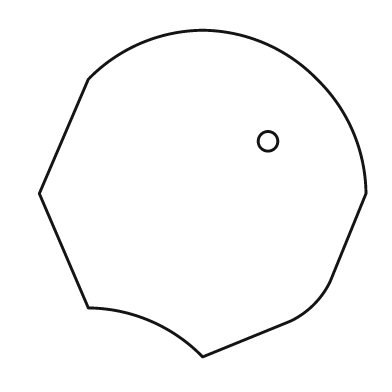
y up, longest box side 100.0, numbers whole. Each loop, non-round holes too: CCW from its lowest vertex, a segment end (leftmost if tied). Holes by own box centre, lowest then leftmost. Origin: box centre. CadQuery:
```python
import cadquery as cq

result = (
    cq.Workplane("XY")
    .moveTo(0.0, -50.0)
    .lineTo(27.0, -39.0)
    .threePointArc((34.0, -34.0), (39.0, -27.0))
    .lineTo(50.0, 0.0)
    .threePointArc((46.0, 19.0), (35.0, 35.0))
    .threePointArc((19.0, 46.0), (0.0, 50.0))
    .threePointArc((-19.0, 46.0), (-35.0, 35.0))
    .lineTo(-50.0, 0.0)
    .lineTo(-35.0, -35.0)
    .threePointArc((-16.0, -39.0), (0.0, -50.0))
    .close()
    .moveTo(20.0, 16.0)
    .circle(3.0)
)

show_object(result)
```